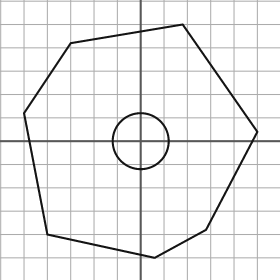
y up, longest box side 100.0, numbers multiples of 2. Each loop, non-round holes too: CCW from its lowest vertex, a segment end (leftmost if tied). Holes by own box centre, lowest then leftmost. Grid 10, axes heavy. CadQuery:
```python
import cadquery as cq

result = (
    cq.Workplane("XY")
    .moveTo(6.0, -50.0)
    .lineTo(28.0, -38.0)
    .lineTo(50.0, 4.0)
    .lineTo(18.0, 50.0)
    .lineTo(-30.0, 42.0)
    .lineTo(-50.0, 12.0)
    .lineTo(-40.0, -40.0)
    .close()
    .moveTo(0.0, 0.0)
    .circle(12.0)
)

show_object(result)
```